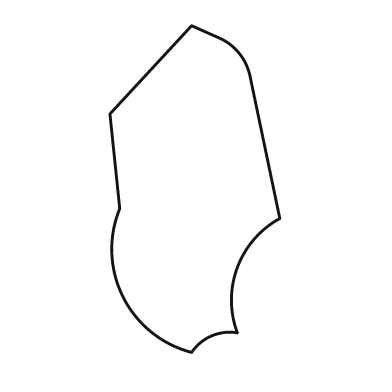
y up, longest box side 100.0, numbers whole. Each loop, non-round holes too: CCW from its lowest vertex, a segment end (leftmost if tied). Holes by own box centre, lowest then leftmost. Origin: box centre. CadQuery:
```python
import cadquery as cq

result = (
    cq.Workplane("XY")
    .moveTo(-1.0, -50.0)
    .threePointArc((5.0, -45.0), (13.0, -44.0))
    .threePointArc((13.0, -24.0), (26.0, -9.0))
    .lineTo(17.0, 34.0)
    .threePointArc((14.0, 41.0), (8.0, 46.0))
    .lineTo(-1.0, 50.0)
    .lineTo(-26.0, 23.0)
    .lineTo(-23.0, -6.0)
    .threePointArc((-22.0, -33.0), (-1.0, -50.0))
    .close()
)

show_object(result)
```